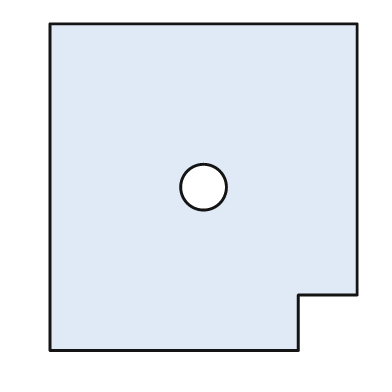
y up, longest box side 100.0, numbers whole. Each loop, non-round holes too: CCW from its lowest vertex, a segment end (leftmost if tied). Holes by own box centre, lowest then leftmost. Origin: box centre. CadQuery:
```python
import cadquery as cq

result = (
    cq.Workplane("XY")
    .moveTo(-47.0, -50.0)
    .lineTo(29.0, -50.0)
    .lineTo(29.0, -33.0)
    .lineTo(47.0, -33.0)
    .lineTo(47.0, 50.0)
    .lineTo(-47.0, 50.0)
    .close()
    .moveTo(0.0, 0.0)
    .circle(7.0)
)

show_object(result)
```